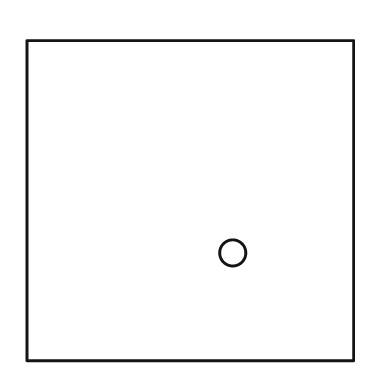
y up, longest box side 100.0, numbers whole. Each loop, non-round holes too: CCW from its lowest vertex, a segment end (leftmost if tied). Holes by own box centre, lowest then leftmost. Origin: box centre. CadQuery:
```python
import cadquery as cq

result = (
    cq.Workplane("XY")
    .moveTo(-50.0, -49.0)
    .lineTo(50.0, -49.0)
    .lineTo(50.0, 49.0)
    .lineTo(-50.0, 49.0)
    .close()
    .moveTo(13.0, -16.0)
    .circle(4.0)
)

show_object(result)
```